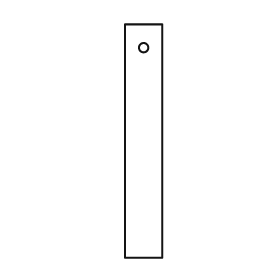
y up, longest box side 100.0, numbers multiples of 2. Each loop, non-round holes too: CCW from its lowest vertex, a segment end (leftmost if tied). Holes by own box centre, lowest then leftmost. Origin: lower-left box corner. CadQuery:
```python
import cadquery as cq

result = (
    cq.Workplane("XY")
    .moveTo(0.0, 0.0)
    .lineTo(16.0, 0.0)
    .lineTo(16.0, 100.0)
    .lineTo(0.0, 100.0)
    .close()
    .moveTo(8.0, 90.0)
    .circle(2.0)
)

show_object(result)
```